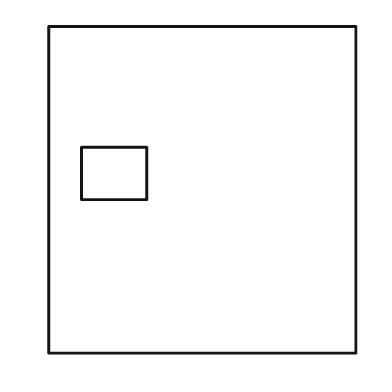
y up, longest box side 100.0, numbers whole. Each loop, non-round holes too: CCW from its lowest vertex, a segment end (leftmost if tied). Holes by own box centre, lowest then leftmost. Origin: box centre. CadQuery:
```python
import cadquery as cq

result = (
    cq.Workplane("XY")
    .moveTo(-47.0, -50.0)
    .lineTo(47.0, -50.0)
    .lineTo(47.0, 50.0)
    .lineTo(-47.0, 50.0)
    .close()
    .moveTo(-37.0, -3.0)
    .lineTo(-17.0, -3.0)
    .lineTo(-17.0, 13.0)
    .lineTo(-37.0, 13.0)
    .close()
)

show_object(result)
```